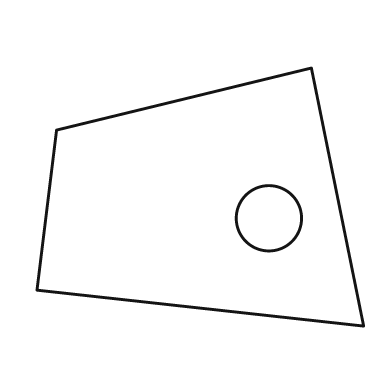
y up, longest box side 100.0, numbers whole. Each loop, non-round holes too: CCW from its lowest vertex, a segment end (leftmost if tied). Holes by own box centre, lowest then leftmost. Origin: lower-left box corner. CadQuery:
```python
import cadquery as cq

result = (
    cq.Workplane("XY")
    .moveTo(100.0, 0.0)
    .lineTo(84.0, 79.0)
    .lineTo(6.0, 60.0)
    .lineTo(0.0, 11.0)
    .close()
    .moveTo(71.0, 33.0)
    .circle(10.0)
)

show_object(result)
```